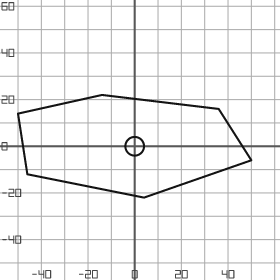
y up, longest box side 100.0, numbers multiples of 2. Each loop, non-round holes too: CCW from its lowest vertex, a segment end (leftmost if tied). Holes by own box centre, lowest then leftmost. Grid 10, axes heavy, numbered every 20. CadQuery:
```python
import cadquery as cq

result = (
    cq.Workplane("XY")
    .moveTo(4.0, -22.0)
    .lineTo(50.0, -6.0)
    .lineTo(36.0, 16.0)
    .lineTo(-14.0, 22.0)
    .lineTo(-50.0, 14.0)
    .lineTo(-46.0, -12.0)
    .close()
    .moveTo(0.0, 0.0)
    .circle(4.0)
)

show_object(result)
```